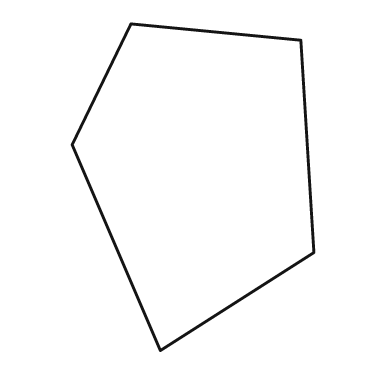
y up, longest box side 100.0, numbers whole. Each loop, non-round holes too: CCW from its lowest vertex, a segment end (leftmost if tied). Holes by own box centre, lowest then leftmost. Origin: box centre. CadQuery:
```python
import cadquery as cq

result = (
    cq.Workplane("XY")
    .moveTo(-10.0, -50.0)
    .lineTo(37.0, -20.0)
    .lineTo(33.0, 45.0)
    .lineTo(-19.0, 50.0)
    .lineTo(-37.0, 13.0)
    .close()
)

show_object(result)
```